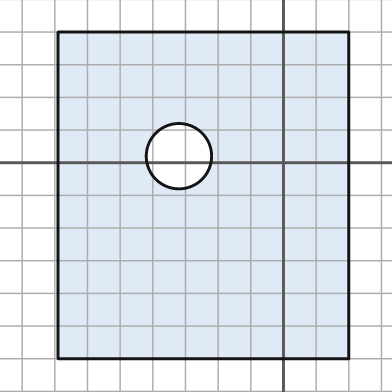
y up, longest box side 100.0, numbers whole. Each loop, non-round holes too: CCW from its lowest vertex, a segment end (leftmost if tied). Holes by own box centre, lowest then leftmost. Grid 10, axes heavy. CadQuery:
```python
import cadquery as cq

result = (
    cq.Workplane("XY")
    .moveTo(-69.0, -60.0)
    .lineTo(20.0, -60.0)
    .lineTo(20.0, 40.0)
    .lineTo(-69.0, 40.0)
    .close()
    .moveTo(-32.0, 2.0)
    .circle(10.0)
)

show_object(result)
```